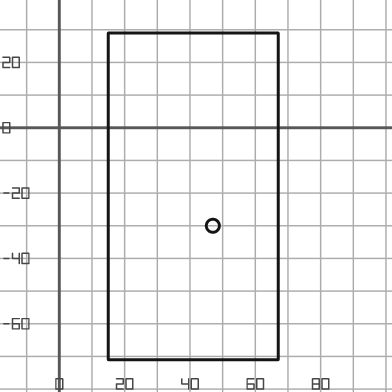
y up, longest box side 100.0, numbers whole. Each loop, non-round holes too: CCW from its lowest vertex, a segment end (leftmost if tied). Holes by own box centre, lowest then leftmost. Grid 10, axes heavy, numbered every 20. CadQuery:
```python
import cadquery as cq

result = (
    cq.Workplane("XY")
    .moveTo(15.0, -71.0)
    .lineTo(67.0, -71.0)
    .lineTo(67.0, 29.0)
    .lineTo(15.0, 29.0)
    .close()
    .moveTo(47.0, -30.0)
    .circle(2.0)
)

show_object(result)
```